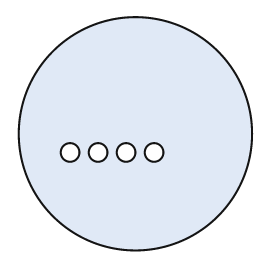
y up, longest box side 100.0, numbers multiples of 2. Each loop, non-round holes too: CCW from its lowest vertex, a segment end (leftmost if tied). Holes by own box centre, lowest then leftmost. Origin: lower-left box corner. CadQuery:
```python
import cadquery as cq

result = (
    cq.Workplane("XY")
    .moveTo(50.0, 50.0)
    .circle(50.0)
    .moveTo(22.0, 42.0)
    .circle(4.0)
    .moveTo(34.0, 42.0)
    .circle(4.0)
    .moveTo(46.0, 42.0)
    .circle(4.0)
    .moveTo(58.0, 42.0)
    .circle(4.0)
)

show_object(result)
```